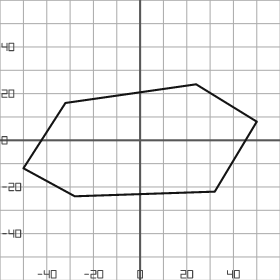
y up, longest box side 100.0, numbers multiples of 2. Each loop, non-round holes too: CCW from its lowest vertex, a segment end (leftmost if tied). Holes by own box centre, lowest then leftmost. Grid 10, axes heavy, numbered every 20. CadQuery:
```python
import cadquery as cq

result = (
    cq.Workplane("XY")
    .moveTo(-28.0, -24.0)
    .lineTo(32.0, -22.0)
    .lineTo(50.0, 8.0)
    .lineTo(24.0, 24.0)
    .lineTo(-32.0, 16.0)
    .lineTo(-50.0, -12.0)
    .close()
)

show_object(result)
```